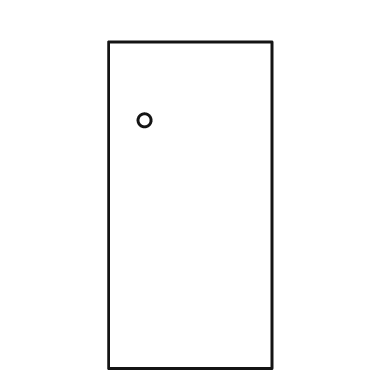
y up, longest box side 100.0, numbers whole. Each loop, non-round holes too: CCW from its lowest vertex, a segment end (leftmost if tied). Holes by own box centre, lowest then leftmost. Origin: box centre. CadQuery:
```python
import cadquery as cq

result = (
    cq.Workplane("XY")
    .moveTo(-25.0, -50.0)
    .lineTo(25.0, -50.0)
    .lineTo(25.0, 50.0)
    .lineTo(-25.0, 50.0)
    .close()
    .moveTo(-14.0, 26.0)
    .circle(2.0)
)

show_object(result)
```